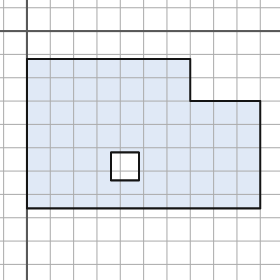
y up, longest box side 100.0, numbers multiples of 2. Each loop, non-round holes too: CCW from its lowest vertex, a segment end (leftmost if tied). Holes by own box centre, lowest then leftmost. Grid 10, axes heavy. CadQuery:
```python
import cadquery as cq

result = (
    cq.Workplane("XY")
    .moveTo(0.0, -76.0)
    .lineTo(100.0, -76.0)
    .lineTo(100.0, -30.0)
    .lineTo(70.0, -30.0)
    .lineTo(70.0, -12.0)
    .lineTo(0.0, -12.0)
    .close()
    .moveTo(36.0, -64.0)
    .lineTo(48.0, -64.0)
    .lineTo(48.0, -52.0)
    .lineTo(36.0, -52.0)
    .close()
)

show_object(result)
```